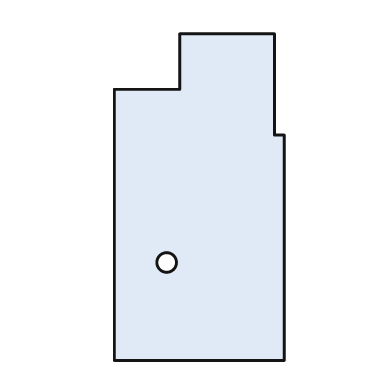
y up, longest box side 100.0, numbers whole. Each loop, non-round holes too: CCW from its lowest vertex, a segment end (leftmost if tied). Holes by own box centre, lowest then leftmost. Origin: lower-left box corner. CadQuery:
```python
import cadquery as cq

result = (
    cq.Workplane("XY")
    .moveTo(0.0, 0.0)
    .lineTo(52.0, 0.0)
    .lineTo(52.0, 69.0)
    .lineTo(49.0, 69.0)
    .lineTo(49.0, 100.0)
    .lineTo(20.0, 100.0)
    .lineTo(20.0, 83.0)
    .lineTo(0.0, 83.0)
    .close()
    .moveTo(16.0, 30.0)
    .circle(3.0)
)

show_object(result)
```